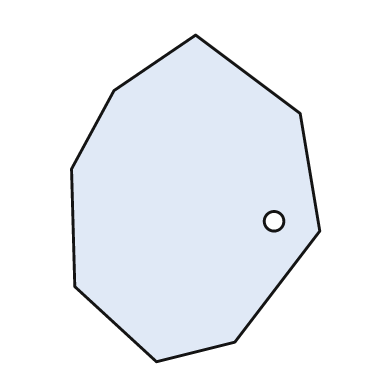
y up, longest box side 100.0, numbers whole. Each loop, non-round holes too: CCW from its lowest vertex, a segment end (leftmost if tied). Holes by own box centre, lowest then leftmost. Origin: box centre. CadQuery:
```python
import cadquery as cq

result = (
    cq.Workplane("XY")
    .moveTo(-12.0, -50.0)
    .lineTo(12.0, -44.0)
    .lineTo(38.0, -10.0)
    .lineTo(32.0, 26.0)
    .lineTo(0.0, 50.0)
    .lineTo(-25.0, 33.0)
    .lineTo(-38.0, 9.0)
    .lineTo(-37.0, -27.0)
    .close()
    .moveTo(24.0, -7.0)
    .circle(3.0)
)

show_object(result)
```